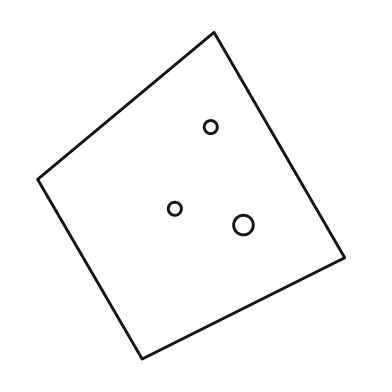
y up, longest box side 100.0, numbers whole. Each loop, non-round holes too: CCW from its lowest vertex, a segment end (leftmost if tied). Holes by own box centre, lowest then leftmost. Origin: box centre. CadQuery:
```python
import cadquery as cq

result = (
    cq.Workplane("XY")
    .moveTo(-15.0, -50.0)
    .lineTo(47.0, -19.0)
    .lineTo(7.0, 50.0)
    .lineTo(-47.0, 5.0)
    .close()
    .moveTo(16.0, -9.0)
    .circle(3.0)
    .moveTo(-5.0, -4.0)
    .circle(2.0)
    .moveTo(6.0, 21.0)
    .circle(2.0)
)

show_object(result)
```